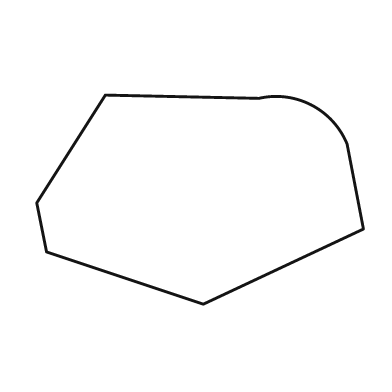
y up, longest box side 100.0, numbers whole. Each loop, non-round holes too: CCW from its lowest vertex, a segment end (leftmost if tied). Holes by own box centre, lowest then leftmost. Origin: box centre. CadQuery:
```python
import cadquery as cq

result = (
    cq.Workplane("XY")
    .moveTo(1.0, -32.0)
    .lineTo(50.0, -9.0)
    .lineTo(45.0, 17.0)
    .threePointArc((34.0, 29.0), (18.0, 31.0))
    .lineTo(-29.0, 32.0)
    .lineTo(-50.0, -1.0)
    .lineTo(-47.0, -16.0)
    .close()
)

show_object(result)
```